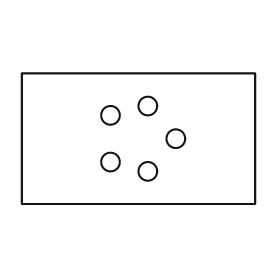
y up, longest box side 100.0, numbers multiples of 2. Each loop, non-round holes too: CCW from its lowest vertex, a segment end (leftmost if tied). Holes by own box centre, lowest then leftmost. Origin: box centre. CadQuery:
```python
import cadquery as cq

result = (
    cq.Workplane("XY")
    .moveTo(-50.0, -28.0)
    .lineTo(50.0, -28.0)
    .lineTo(50.0, 28.0)
    .lineTo(-50.0, 28.0)
    .close()
    .moveTo(4.0, -14.0)
    .circle(4.0)
    .moveTo(-12.0, -10.0)
    .circle(4.0)
    .moveTo(16.0, 0.0)
    .circle(4.0)
    .moveTo(-12.0, 10.0)
    .circle(4.0)
    .moveTo(4.0, 14.0)
    .circle(4.0)
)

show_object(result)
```